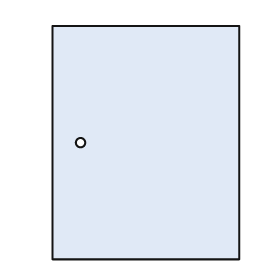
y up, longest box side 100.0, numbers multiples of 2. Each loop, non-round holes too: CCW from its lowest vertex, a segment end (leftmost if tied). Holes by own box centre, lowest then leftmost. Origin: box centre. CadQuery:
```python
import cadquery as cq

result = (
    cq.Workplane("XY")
    .moveTo(-40.0, -50.0)
    .lineTo(40.0, -50.0)
    .lineTo(40.0, 50.0)
    .lineTo(-40.0, 50.0)
    .close()
    .moveTo(-28.0, 0.0)
    .circle(2.0)
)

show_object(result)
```